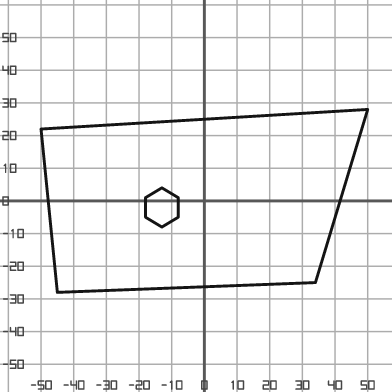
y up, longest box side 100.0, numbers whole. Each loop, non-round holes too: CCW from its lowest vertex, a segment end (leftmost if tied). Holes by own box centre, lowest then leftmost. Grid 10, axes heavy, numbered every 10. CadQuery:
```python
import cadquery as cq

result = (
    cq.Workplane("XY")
    .moveTo(-45.0, -28.0)
    .lineTo(34.0, -25.0)
    .lineTo(50.0, 28.0)
    .lineTo(-50.0, 22.0)
    .close()
    .moveTo(-13.0, -8.0)
    .lineTo(-8.0, -5.0)
    .lineTo(-8.0, 1.0)
    .lineTo(-13.0, 4.0)
    .lineTo(-18.0, 1.0)
    .lineTo(-18.0, -5.0)
    .close()
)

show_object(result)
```